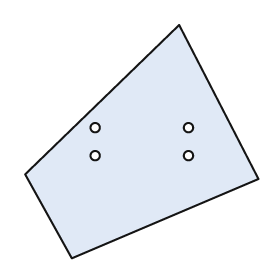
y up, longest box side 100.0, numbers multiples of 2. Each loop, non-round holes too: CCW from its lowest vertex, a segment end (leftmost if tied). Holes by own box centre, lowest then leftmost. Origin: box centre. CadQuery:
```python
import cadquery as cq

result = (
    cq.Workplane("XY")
    .moveTo(-30.0, -50.0)
    .lineTo(50.0, -16.0)
    .lineTo(16.0, 50.0)
    .lineTo(-50.0, -14.0)
    .close()
    .moveTo(-20.0, -6.0)
    .circle(2.0)
    .moveTo(20.0, -6.0)
    .circle(2.0)
    .moveTo(-20.0, 6.0)
    .circle(2.0)
    .moveTo(20.0, 6.0)
    .circle(2.0)
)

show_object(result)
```